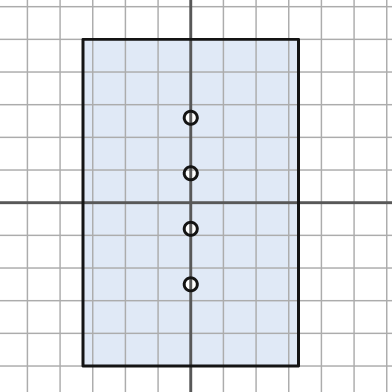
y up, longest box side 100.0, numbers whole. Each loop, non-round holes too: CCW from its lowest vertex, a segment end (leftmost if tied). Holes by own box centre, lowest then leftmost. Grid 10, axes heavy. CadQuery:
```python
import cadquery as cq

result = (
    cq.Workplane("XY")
    .moveTo(-33.0, -50.0)
    .lineTo(33.0, -50.0)
    .lineTo(33.0, 50.0)
    .lineTo(-33.0, 50.0)
    .close()
    .moveTo(0.0, -25.0)
    .circle(2.0)
    .moveTo(0.0, -8.0)
    .circle(2.0)
    .moveTo(0.0, 9.0)
    .circle(2.0)
    .moveTo(0.0, 26.0)
    .circle(2.0)
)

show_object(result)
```